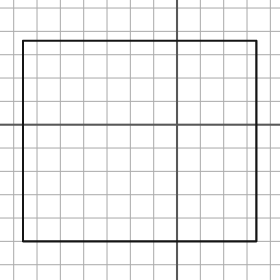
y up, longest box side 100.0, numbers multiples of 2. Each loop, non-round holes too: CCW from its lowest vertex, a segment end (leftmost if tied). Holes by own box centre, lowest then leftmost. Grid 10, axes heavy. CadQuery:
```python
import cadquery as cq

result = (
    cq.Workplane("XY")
    .moveTo(-66.0, -50.0)
    .lineTo(34.0, -50.0)
    .lineTo(34.0, 36.0)
    .lineTo(-66.0, 36.0)
    .close()
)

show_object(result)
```